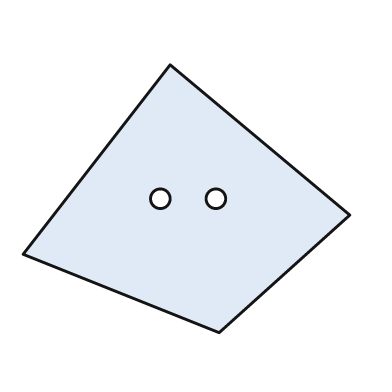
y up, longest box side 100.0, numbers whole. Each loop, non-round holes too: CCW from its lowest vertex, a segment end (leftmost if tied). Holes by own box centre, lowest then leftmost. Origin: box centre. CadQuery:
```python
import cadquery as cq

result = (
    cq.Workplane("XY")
    .moveTo(10.0, -41.0)
    .lineTo(50.0, -5.0)
    .lineTo(-5.0, 41.0)
    .lineTo(-50.0, -17.0)
    .close()
    .moveTo(-8.0, 0.0)
    .circle(3.0)
    .moveTo(9.0, 0.0)
    .circle(3.0)
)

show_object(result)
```